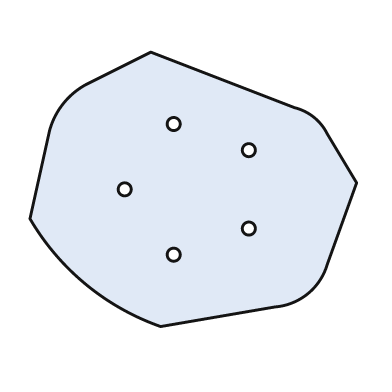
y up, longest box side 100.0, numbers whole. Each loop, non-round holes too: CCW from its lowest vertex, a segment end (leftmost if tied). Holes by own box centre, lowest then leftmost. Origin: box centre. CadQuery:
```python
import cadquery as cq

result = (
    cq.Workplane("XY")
    .moveTo(-10.0, -42.0)
    .lineTo(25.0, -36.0)
    .threePointArc((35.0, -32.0), (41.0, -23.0))
    .lineTo(50.0, 2.0)
    .lineTo(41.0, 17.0)
    .threePointArc((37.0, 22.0), (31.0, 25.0))
    .lineTo(-13.0, 42.0)
    .lineTo(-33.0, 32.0)
    .threePointArc((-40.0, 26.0), (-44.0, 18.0))
    .lineTo(-50.0, -9.0)
    .threePointArc((-33.0, -29.0), (-10.0, -42.0))
    .close()
    .moveTo(-6.0, -20.0)
    .circle(2.0)
    .moveTo(17.0, -12.0)
    .circle(2.0)
    .moveTo(-21.0, 0.0)
    .circle(2.0)
    .moveTo(17.0, 12.0)
    .circle(2.0)
    .moveTo(-6.0, 20.0)
    .circle(2.0)
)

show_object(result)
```